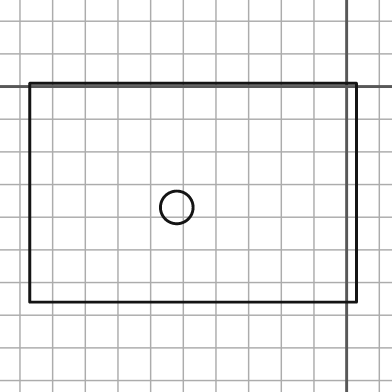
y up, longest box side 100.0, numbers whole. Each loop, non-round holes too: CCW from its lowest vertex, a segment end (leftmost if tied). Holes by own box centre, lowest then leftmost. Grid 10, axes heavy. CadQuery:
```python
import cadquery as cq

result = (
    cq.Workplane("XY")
    .moveTo(-97.0, -66.0)
    .lineTo(3.0, -66.0)
    .lineTo(3.0, 1.0)
    .lineTo(-97.0, 1.0)
    .close()
    .moveTo(-52.0, -37.0)
    .circle(5.0)
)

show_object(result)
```